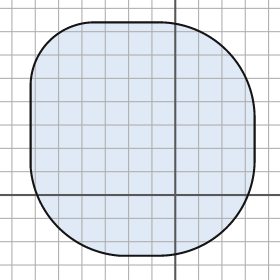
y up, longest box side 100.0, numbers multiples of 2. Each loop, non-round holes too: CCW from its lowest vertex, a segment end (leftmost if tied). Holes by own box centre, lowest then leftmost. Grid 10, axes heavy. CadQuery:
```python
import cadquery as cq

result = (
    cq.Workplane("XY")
    .moveTo(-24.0, -26.0)
    .lineTo(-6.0, -26.0)
    .threePointArc((22.0, -14.0), (34.0, 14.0))
    .lineTo(34.0, 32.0)
    .threePointArc((22.0, 62.0), (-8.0, 74.0))
    .lineTo(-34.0, 74.0)
    .threePointArc((-54.0, 66.0), (-62.0, 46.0))
    .lineTo(-62.0, 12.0)
    .threePointArc((-50.0, -14.0), (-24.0, -26.0))
    .close()
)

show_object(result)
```